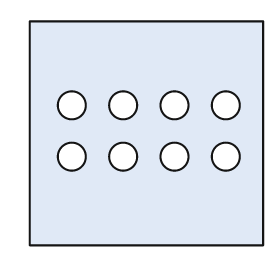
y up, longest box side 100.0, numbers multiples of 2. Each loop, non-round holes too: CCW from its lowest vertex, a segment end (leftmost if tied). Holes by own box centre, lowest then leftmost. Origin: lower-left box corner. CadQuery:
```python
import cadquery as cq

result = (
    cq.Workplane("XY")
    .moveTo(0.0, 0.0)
    .lineTo(100.0, 0.0)
    .lineTo(100.0, 96.0)
    .lineTo(0.0, 96.0)
    .close()
    .moveTo(18.0, 38.0)
    .circle(6.0)
    .moveTo(40.0, 38.0)
    .circle(6.0)
    .moveTo(62.0, 38.0)
    .circle(6.0)
    .moveTo(84.0, 38.0)
    .circle(6.0)
    .moveTo(18.0, 60.0)
    .circle(6.0)
    .moveTo(40.0, 60.0)
    .circle(6.0)
    .moveTo(62.0, 60.0)
    .circle(6.0)
    .moveTo(84.0, 60.0)
    .circle(6.0)
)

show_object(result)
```